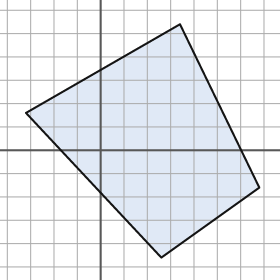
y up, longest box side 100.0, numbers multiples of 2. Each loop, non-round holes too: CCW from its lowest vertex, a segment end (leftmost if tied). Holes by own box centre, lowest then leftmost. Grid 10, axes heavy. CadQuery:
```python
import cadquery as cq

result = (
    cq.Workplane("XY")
    .moveTo(26.0, -46.0)
    .lineTo(68.0, -16.0)
    .lineTo(34.0, 54.0)
    .lineTo(-32.0, 16.0)
    .close()
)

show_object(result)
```